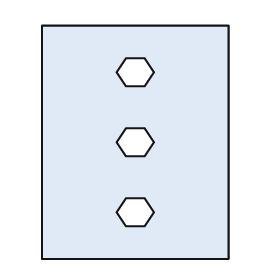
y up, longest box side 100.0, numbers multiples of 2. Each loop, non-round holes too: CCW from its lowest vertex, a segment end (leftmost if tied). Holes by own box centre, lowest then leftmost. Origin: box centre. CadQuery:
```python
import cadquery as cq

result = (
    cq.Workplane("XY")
    .moveTo(-40.0, -50.0)
    .lineTo(40.0, -50.0)
    .lineTo(40.0, 50.0)
    .lineTo(-40.0, 50.0)
    .close()
    .moveTo(-4.0, -36.0)
    .lineTo(4.0, -36.0)
    .lineTo(8.0, -30.0)
    .lineTo(4.0, -24.0)
    .lineTo(-4.0, -24.0)
    .lineTo(-8.0, -30.0)
    .close()
    .moveTo(-4.0, -6.0)
    .lineTo(4.0, -6.0)
    .lineTo(8.0, 0.0)
    .lineTo(4.0, 6.0)
    .lineTo(-4.0, 6.0)
    .lineTo(-8.0, 0.0)
    .close()
    .moveTo(-4.0, 24.0)
    .lineTo(4.0, 24.0)
    .lineTo(8.0, 30.0)
    .lineTo(4.0, 36.0)
    .lineTo(-4.0, 36.0)
    .lineTo(-8.0, 30.0)
    .close()
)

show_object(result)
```